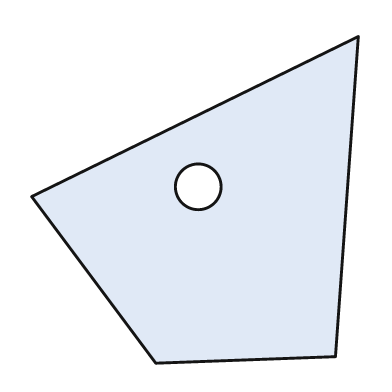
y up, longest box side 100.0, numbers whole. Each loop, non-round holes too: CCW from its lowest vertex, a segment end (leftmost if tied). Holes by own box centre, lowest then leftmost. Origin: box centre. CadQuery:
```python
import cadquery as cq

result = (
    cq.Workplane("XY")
    .moveTo(-12.0, -50.0)
    .lineTo(43.0, -48.0)
    .lineTo(50.0, 50.0)
    .lineTo(-50.0, 1.0)
    .close()
    .moveTo(1.0, 4.0)
    .circle(7.0)
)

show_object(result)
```